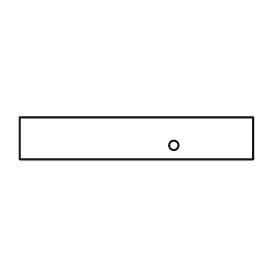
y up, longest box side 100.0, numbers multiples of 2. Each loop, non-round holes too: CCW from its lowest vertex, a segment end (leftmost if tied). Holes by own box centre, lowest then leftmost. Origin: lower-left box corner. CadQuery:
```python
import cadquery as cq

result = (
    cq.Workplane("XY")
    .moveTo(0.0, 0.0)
    .lineTo(100.0, 0.0)
    .lineTo(100.0, 18.0)
    .lineTo(0.0, 18.0)
    .close()
    .moveTo(66.0, 6.0)
    .circle(2.0)
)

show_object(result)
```